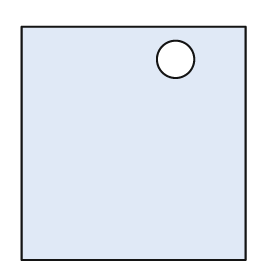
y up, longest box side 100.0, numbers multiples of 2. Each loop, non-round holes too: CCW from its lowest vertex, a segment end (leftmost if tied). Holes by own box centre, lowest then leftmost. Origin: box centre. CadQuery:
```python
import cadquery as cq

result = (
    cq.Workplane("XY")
    .moveTo(-48.0, -50.0)
    .lineTo(48.0, -50.0)
    .lineTo(48.0, 50.0)
    .lineTo(-48.0, 50.0)
    .close()
    .moveTo(18.0, 36.0)
    .circle(8.0)
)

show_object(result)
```